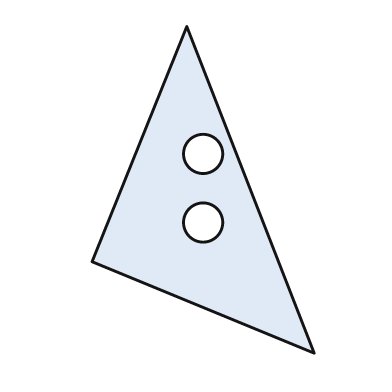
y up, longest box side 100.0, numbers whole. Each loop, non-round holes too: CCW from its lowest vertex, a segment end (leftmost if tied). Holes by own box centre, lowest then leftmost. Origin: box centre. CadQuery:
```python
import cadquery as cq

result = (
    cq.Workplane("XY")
    .moveTo(34.0, -50.0)
    .lineTo(-5.0, 50.0)
    .lineTo(-34.0, -22.0)
    .close()
    .moveTo(0.0, -10.0)
    .circle(6.0)
    .moveTo(0.0, 11.0)
    .circle(6.0)
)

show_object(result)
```